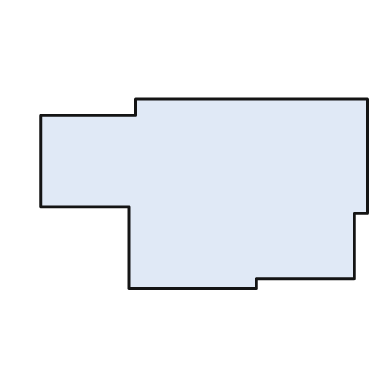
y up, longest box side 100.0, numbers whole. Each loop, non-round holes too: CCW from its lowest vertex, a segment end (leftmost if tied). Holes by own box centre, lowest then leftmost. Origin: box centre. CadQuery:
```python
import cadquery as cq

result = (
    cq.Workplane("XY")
    .moveTo(-23.0, -29.0)
    .lineTo(16.0, -29.0)
    .lineTo(16.0, -26.0)
    .lineTo(46.0, -26.0)
    .lineTo(46.0, -6.0)
    .lineTo(50.0, -6.0)
    .lineTo(50.0, 29.0)
    .lineTo(-21.0, 29.0)
    .lineTo(-21.0, 24.0)
    .lineTo(-50.0, 24.0)
    .lineTo(-50.0, -4.0)
    .lineTo(-23.0, -4.0)
    .close()
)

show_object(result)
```